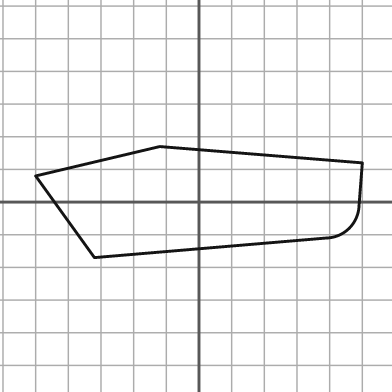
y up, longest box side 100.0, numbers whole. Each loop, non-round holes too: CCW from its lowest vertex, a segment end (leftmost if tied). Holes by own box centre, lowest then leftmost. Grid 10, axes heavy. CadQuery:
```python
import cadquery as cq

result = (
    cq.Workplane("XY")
    .moveTo(-32.0, -17.0)
    .lineTo(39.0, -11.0)
    .threePointArc((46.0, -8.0), (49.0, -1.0))
    .lineTo(50.0, 12.0)
    .lineTo(-12.0, 17.0)
    .lineTo(-50.0, 8.0)
    .close()
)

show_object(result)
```